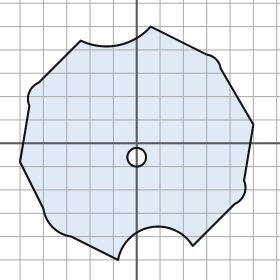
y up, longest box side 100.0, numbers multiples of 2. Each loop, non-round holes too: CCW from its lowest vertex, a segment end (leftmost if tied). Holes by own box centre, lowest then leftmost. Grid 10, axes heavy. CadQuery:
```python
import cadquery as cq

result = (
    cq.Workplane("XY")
    .moveTo(-8.0, -50.0)
    .threePointArc((6.0, -36.0), (24.0, -44.0))
    .lineTo(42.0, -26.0)
    .threePointArc((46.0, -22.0), (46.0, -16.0))
    .lineTo(50.0, 8.0)
    .lineTo(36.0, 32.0)
    .threePointArc((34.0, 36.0), (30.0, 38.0))
    .lineTo(6.0, 50.0)
    .threePointArc((-8.0, 42.0), (-24.0, 44.0))
    .lineTo(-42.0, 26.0)
    .threePointArc((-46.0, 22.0), (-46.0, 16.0))
    .lineTo(-50.0, -8.0)
    .lineTo(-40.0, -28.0)
    .threePointArc((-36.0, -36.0), (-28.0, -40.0))
    .close()
    .moveTo(0.0, -6.0)
    .circle(4.0)
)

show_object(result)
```